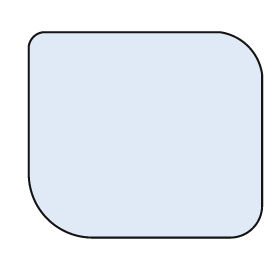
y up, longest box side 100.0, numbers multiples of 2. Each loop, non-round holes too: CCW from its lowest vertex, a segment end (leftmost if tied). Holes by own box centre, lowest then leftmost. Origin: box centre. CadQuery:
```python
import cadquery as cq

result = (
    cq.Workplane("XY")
    .moveTo(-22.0, -44.0)
    .lineTo(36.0, -44.0)
    .threePointArc((46.0, -40.0), (50.0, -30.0))
    .lineTo(50.0, 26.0)
    .threePointArc((44.0, 38.0), (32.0, 44.0))
    .lineTo(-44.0, 44.0)
    .threePointArc((-48.0, 42.0), (-50.0, 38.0))
    .lineTo(-50.0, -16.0)
    .threePointArc((-42.0, -36.0), (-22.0, -44.0))
    .close()
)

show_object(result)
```